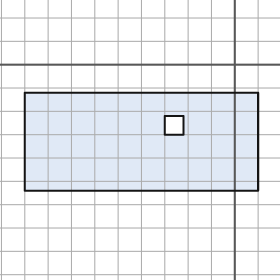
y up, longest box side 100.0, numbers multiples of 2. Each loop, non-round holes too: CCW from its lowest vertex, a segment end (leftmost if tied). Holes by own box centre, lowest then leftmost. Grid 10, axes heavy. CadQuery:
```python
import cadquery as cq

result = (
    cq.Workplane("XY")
    .moveTo(-90.0, -54.0)
    .lineTo(10.0, -54.0)
    .lineTo(10.0, -12.0)
    .lineTo(-90.0, -12.0)
    .close()
    .moveTo(-30.0, -30.0)
    .lineTo(-22.0, -30.0)
    .lineTo(-22.0, -22.0)
    .lineTo(-30.0, -22.0)
    .close()
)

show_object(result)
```